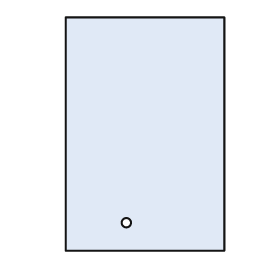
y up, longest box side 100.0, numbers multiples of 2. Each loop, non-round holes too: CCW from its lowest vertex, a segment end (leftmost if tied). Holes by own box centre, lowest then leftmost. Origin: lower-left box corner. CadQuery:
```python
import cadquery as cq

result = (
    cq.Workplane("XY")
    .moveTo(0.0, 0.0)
    .lineTo(68.0, 0.0)
    .lineTo(68.0, 100.0)
    .lineTo(0.0, 100.0)
    .close()
    .moveTo(26.0, 12.0)
    .circle(2.0)
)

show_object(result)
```